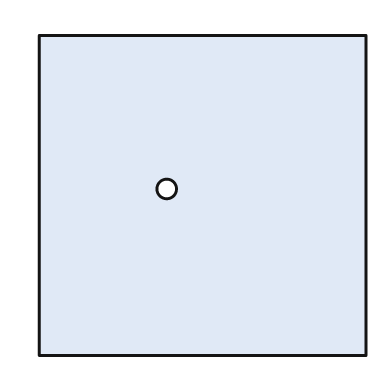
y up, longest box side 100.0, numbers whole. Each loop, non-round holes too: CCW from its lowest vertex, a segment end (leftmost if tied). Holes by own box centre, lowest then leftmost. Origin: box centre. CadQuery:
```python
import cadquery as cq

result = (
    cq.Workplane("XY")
    .moveTo(-50.0, -49.0)
    .lineTo(50.0, -49.0)
    .lineTo(50.0, 49.0)
    .lineTo(-50.0, 49.0)
    .close()
    .moveTo(-11.0, 2.0)
    .circle(3.0)
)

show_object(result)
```